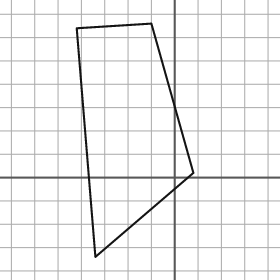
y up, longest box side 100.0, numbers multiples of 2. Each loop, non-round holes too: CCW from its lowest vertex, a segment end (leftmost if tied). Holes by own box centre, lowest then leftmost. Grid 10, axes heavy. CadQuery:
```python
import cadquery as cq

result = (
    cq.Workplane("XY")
    .moveTo(-34.0, -34.0)
    .lineTo(8.0, 2.0)
    .lineTo(-10.0, 66.0)
    .lineTo(-42.0, 64.0)
    .close()
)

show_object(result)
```